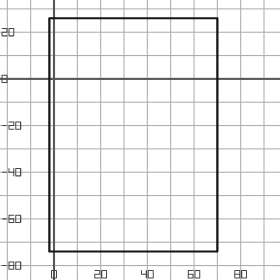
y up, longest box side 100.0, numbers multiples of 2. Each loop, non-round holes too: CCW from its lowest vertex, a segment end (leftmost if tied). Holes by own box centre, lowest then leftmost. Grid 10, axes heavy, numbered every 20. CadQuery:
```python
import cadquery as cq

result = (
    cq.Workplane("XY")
    .moveTo(-2.0, -74.0)
    .lineTo(70.0, -74.0)
    .lineTo(70.0, 26.0)
    .lineTo(-2.0, 26.0)
    .close()
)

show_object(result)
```